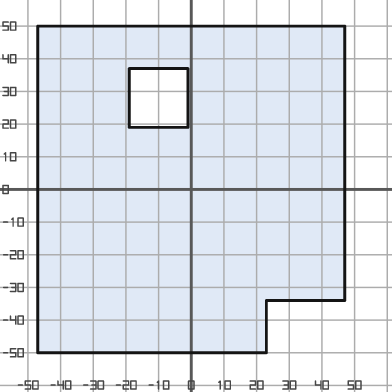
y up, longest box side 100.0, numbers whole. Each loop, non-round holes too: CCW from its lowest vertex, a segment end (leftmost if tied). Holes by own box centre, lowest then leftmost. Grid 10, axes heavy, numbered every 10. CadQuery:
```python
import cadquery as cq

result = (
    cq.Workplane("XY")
    .moveTo(-47.0, -50.0)
    .lineTo(23.0, -50.0)
    .lineTo(23.0, -34.0)
    .lineTo(47.0, -34.0)
    .lineTo(47.0, 50.0)
    .lineTo(-47.0, 50.0)
    .close()
    .moveTo(-19.0, 19.0)
    .lineTo(-1.0, 19.0)
    .lineTo(-1.0, 37.0)
    .lineTo(-19.0, 37.0)
    .close()
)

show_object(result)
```